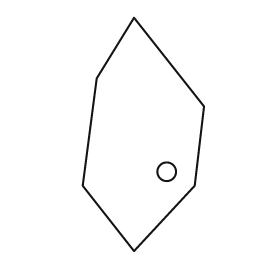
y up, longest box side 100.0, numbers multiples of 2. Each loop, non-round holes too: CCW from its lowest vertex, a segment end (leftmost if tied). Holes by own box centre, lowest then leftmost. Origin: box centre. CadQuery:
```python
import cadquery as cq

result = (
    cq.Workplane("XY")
    .moveTo(-4.0, -50.0)
    .lineTo(22.0, -22.0)
    .lineTo(26.0, 12.0)
    .lineTo(-4.0, 50.0)
    .lineTo(-20.0, 24.0)
    .lineTo(-26.0, -22.0)
    .close()
    .moveTo(10.0, -16.0)
    .circle(4.0)
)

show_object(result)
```